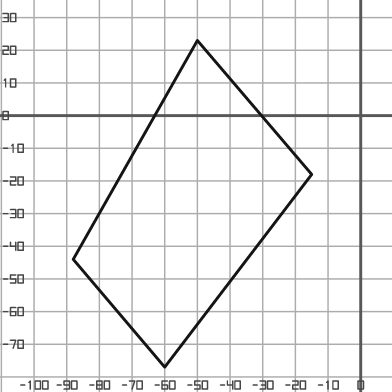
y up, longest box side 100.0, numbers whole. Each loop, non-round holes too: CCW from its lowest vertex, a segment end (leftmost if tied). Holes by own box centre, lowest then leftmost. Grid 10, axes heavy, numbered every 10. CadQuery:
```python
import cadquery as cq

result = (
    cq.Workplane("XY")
    .moveTo(-60.0, -77.0)
    .lineTo(-15.0, -18.0)
    .lineTo(-50.0, 23.0)
    .lineTo(-88.0, -44.0)
    .close()
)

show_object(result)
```